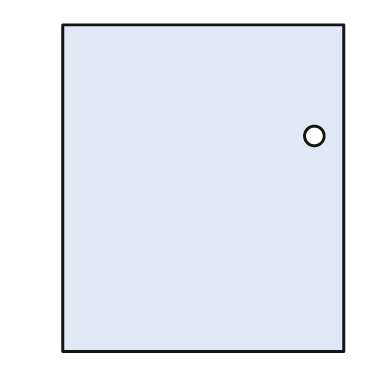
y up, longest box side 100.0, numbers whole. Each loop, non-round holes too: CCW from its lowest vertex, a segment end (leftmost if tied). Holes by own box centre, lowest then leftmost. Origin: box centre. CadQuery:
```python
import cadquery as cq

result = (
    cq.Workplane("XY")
    .moveTo(-43.0, -50.0)
    .lineTo(43.0, -50.0)
    .lineTo(43.0, 50.0)
    .lineTo(-43.0, 50.0)
    .close()
    .moveTo(34.0, 16.0)
    .circle(3.0)
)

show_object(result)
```